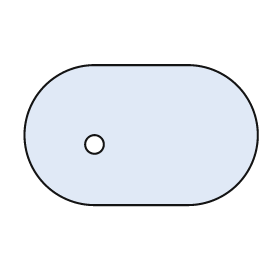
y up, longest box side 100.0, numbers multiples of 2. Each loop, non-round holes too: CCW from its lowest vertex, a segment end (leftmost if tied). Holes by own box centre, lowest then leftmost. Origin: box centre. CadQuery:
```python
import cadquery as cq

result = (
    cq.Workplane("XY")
    .moveTo(-20.0, -30.0)
    .lineTo(20.0, -30.0)
    .threePointArc((50.0, 0.0), (20.0, 30.0))
    .lineTo(-20.0, 30.0)
    .threePointArc((-50.0, 0.0), (-20.0, -30.0))
    .close()
    .moveTo(-20.0, -4.0)
    .circle(4.0)
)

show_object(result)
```